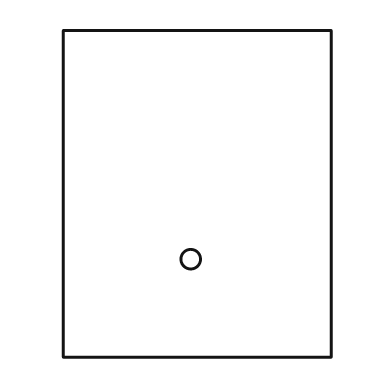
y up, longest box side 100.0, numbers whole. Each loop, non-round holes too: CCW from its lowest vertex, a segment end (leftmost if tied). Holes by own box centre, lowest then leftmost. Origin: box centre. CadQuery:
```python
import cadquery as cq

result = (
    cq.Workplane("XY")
    .moveTo(-41.0, -50.0)
    .lineTo(41.0, -50.0)
    .lineTo(41.0, 50.0)
    .lineTo(-41.0, 50.0)
    .close()
    .moveTo(-2.0, -20.0)
    .circle(3.0)
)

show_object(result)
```